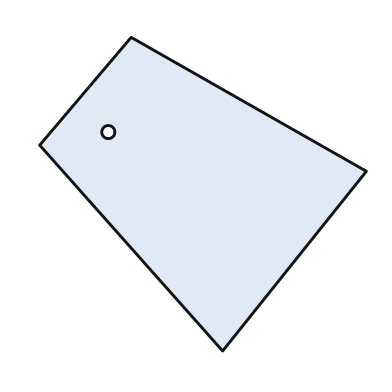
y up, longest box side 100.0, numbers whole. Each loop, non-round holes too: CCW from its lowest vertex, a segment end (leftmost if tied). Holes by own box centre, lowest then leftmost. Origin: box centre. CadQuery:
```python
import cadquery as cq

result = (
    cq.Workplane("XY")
    .moveTo(6.0, -48.0)
    .lineTo(50.0, 7.0)
    .lineTo(-22.0, 48.0)
    .lineTo(-50.0, 15.0)
    .close()
    .moveTo(-29.0, 19.0)
    .circle(2.0)
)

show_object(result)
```